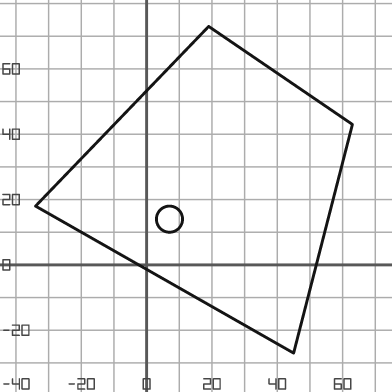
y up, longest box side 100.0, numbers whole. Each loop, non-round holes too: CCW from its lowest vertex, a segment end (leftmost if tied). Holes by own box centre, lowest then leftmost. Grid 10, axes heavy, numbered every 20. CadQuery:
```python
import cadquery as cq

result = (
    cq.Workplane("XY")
    .moveTo(45.0, -27.0)
    .lineTo(63.0, 43.0)
    .lineTo(19.0, 73.0)
    .lineTo(-34.0, 18.0)
    .close()
    .moveTo(7.0, 14.0)
    .circle(4.0)
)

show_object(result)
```